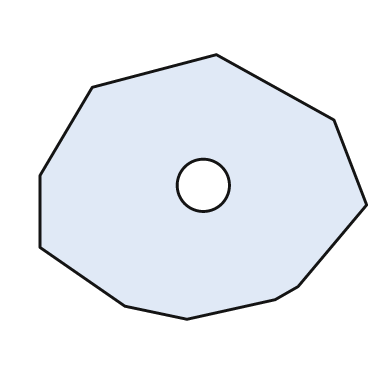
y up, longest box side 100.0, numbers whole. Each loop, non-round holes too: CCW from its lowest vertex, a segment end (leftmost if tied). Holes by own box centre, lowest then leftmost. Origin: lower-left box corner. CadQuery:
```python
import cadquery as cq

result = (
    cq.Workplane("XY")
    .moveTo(45.0, 0.0)
    .lineTo(72.0, 6.0)
    .lineTo(79.0, 10.0)
    .lineTo(100.0, 35.0)
    .lineTo(90.0, 61.0)
    .lineTo(54.0, 81.0)
    .lineTo(16.0, 71.0)
    .lineTo(0.0, 44.0)
    .lineTo(0.0, 22.0)
    .lineTo(26.0, 4.0)
    .close()
    .moveTo(50.0, 41.0)
    .circle(8.0)
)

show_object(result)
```